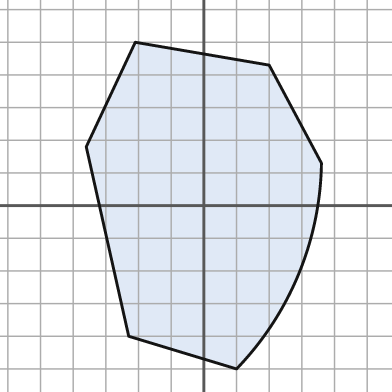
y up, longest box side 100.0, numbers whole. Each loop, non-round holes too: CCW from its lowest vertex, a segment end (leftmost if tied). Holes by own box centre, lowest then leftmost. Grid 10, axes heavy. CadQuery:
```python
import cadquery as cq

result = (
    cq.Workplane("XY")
    .moveTo(10.0, -50.0)
    .threePointArc((29.0, -21.0), (36.0, 13.0))
    .lineTo(20.0, 43.0)
    .lineTo(-21.0, 50.0)
    .lineTo(-36.0, 18.0)
    .lineTo(-23.0, -40.0)
    .close()
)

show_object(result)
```